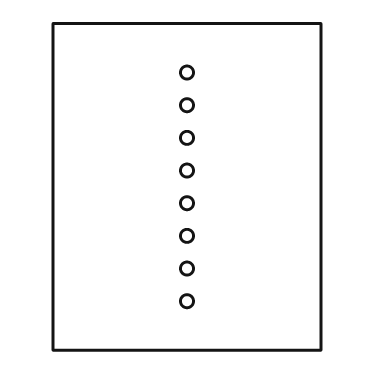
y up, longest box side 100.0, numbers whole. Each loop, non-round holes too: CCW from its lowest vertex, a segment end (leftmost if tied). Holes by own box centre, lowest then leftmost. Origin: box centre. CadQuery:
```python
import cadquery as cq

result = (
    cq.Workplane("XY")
    .moveTo(-41.0, -50.0)
    .lineTo(41.0, -50.0)
    .lineTo(41.0, 50.0)
    .lineTo(-41.0, 50.0)
    .close()
    .moveTo(0.0, -35.0)
    .circle(2.0)
    .moveTo(0.0, -25.0)
    .circle(2.0)
    .moveTo(0.0, -15.0)
    .circle(2.0)
    .moveTo(0.0, -5.0)
    .circle(2.0)
    .moveTo(0.0, 5.0)
    .circle(2.0)
    .moveTo(0.0, 15.0)
    .circle(2.0)
    .moveTo(0.0, 25.0)
    .circle(2.0)
    .moveTo(0.0, 35.0)
    .circle(2.0)
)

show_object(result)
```